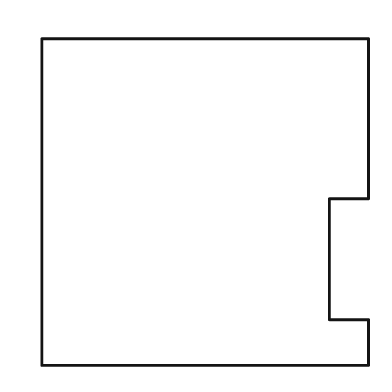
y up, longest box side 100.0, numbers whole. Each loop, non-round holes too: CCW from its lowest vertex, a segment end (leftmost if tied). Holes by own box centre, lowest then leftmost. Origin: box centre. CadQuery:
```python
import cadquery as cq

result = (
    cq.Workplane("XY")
    .moveTo(-50.0, -50.0)
    .lineTo(50.0, -50.0)
    .lineTo(50.0, -36.0)
    .lineTo(38.0, -36.0)
    .lineTo(38.0, 1.0)
    .lineTo(50.0, 1.0)
    .lineTo(50.0, 50.0)
    .lineTo(-50.0, 50.0)
    .close()
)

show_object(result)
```